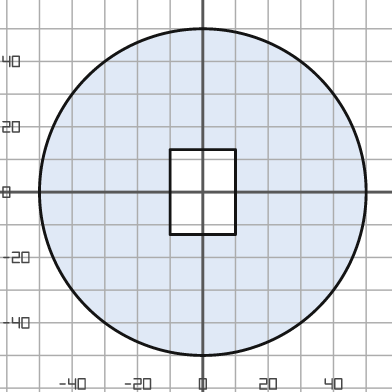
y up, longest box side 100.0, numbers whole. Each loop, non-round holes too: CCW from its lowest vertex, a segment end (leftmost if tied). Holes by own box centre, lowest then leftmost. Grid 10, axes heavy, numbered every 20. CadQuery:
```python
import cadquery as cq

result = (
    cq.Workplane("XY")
    .moveTo(0.0, 0.0)
    .circle(50.0)
    .moveTo(-10.0, -13.0)
    .lineTo(10.0, -13.0)
    .lineTo(10.0, 13.0)
    .lineTo(-10.0, 13.0)
    .close()
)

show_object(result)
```